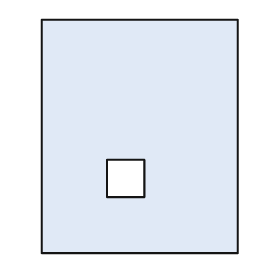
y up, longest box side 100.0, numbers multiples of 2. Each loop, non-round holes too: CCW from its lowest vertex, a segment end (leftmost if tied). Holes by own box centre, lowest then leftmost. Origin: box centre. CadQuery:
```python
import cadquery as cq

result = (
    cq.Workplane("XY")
    .moveTo(-42.0, -50.0)
    .lineTo(42.0, -50.0)
    .lineTo(42.0, 50.0)
    .lineTo(-42.0, 50.0)
    .close()
    .moveTo(-14.0, -26.0)
    .lineTo(2.0, -26.0)
    .lineTo(2.0, -10.0)
    .lineTo(-14.0, -10.0)
    .close()
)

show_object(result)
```